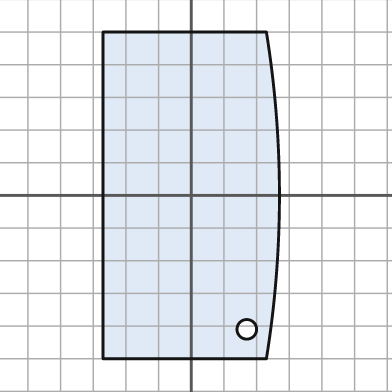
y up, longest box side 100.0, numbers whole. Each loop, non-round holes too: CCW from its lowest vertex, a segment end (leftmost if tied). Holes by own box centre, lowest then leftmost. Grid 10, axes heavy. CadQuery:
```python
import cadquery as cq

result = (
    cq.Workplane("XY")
    .moveTo(-27.0, -50.0)
    .lineTo(23.0, -50.0)
    .threePointArc((27.0, 0.0), (23.0, 50.0))
    .lineTo(-27.0, 50.0)
    .close()
    .moveTo(17.0, -41.0)
    .circle(3.0)
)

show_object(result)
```